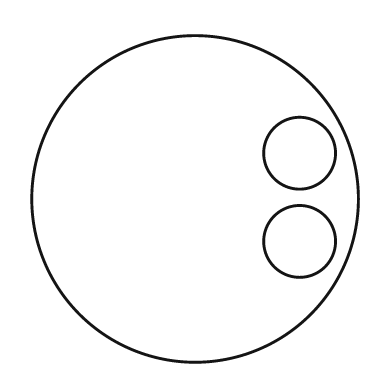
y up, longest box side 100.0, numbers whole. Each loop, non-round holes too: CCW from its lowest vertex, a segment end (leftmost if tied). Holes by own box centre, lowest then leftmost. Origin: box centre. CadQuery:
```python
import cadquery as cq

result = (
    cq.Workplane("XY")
    .moveTo(0.0, 0.0)
    .circle(50.0)
    .moveTo(32.0, -13.0)
    .circle(11.0)
    .moveTo(32.0, 14.0)
    .circle(11.0)
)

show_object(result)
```